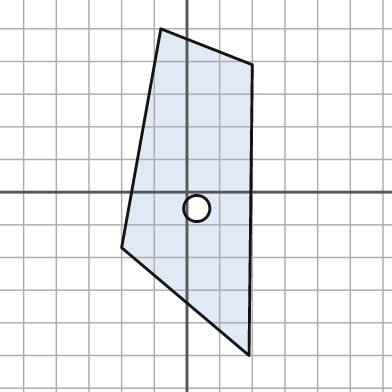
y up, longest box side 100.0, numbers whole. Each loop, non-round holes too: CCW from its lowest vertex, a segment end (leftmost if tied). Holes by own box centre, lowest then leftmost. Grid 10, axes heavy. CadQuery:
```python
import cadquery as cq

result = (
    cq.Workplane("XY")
    .moveTo(19.0, -50.0)
    .lineTo(20.0, 39.0)
    .lineTo(-8.0, 50.0)
    .lineTo(-20.0, -17.0)
    .close()
    .moveTo(3.0, -5.0)
    .circle(4.0)
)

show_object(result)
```